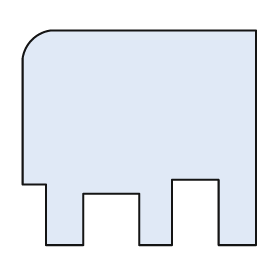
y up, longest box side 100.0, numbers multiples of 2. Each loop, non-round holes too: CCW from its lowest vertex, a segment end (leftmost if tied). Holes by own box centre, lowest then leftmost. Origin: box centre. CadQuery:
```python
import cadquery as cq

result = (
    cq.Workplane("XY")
    .moveTo(-40.0, -46.0)
    .lineTo(-24.0, -46.0)
    .lineTo(-24.0, -24.0)
    .lineTo(0.0, -24.0)
    .lineTo(0.0, -46.0)
    .lineTo(14.0, -46.0)
    .lineTo(14.0, -18.0)
    .lineTo(34.0, -18.0)
    .lineTo(34.0, -46.0)
    .lineTo(50.0, -46.0)
    .lineTo(50.0, 46.0)
    .lineTo(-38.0, 46.0)
    .threePointArc((-46.0, 42.0), (-50.0, 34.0))
    .lineTo(-50.0, -20.0)
    .lineTo(-40.0, -20.0)
    .close()
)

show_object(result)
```